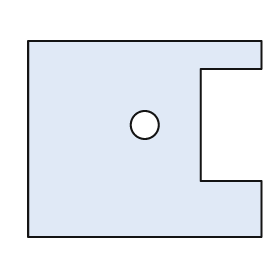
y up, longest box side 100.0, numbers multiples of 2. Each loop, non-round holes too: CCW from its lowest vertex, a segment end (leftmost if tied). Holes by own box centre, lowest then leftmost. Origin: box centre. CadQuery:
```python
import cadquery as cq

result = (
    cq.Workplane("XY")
    .moveTo(-50.0, -42.0)
    .lineTo(50.0, -42.0)
    .lineTo(50.0, -18.0)
    .lineTo(24.0, -18.0)
    .lineTo(24.0, 30.0)
    .lineTo(50.0, 30.0)
    .lineTo(50.0, 42.0)
    .lineTo(-50.0, 42.0)
    .close()
    .moveTo(0.0, 6.0)
    .circle(6.0)
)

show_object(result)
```